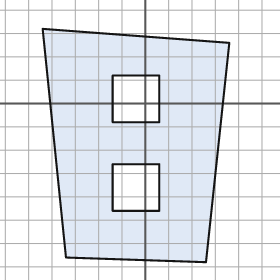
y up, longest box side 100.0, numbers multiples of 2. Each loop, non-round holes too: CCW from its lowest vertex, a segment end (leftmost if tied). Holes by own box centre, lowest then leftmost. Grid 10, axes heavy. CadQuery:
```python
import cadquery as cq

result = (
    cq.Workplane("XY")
    .moveTo(26.0, -68.0)
    .lineTo(36.0, 26.0)
    .lineTo(-44.0, 32.0)
    .lineTo(-34.0, -66.0)
    .close()
    .moveTo(-14.0, -46.0)
    .lineTo(6.0, -46.0)
    .lineTo(6.0, -26.0)
    .lineTo(-14.0, -26.0)
    .close()
    .moveTo(-14.0, -8.0)
    .lineTo(6.0, -8.0)
    .lineTo(6.0, 12.0)
    .lineTo(-14.0, 12.0)
    .close()
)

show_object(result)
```